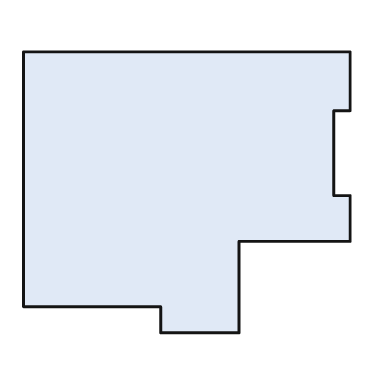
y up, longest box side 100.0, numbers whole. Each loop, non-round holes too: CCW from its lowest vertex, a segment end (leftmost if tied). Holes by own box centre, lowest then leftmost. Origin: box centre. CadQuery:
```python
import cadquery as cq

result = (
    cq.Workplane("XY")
    .moveTo(-8.0, -43.0)
    .lineTo(16.0, -43.0)
    .lineTo(16.0, -15.0)
    .lineTo(50.0, -15.0)
    .lineTo(50.0, -1.0)
    .lineTo(45.0, -1.0)
    .lineTo(45.0, 25.0)
    .lineTo(50.0, 25.0)
    .lineTo(50.0, 43.0)
    .lineTo(-50.0, 43.0)
    .lineTo(-50.0, -35.0)
    .lineTo(-8.0, -35.0)
    .close()
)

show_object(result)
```